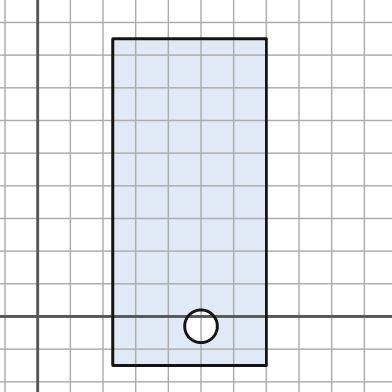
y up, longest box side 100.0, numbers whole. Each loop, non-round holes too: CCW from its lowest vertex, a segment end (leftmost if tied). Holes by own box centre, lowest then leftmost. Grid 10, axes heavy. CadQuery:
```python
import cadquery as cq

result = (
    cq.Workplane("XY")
    .moveTo(23.0, -15.0)
    .lineTo(70.0, -15.0)
    .lineTo(70.0, 85.0)
    .lineTo(23.0, 85.0)
    .close()
    .moveTo(50.0, -3.0)
    .circle(5.0)
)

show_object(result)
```